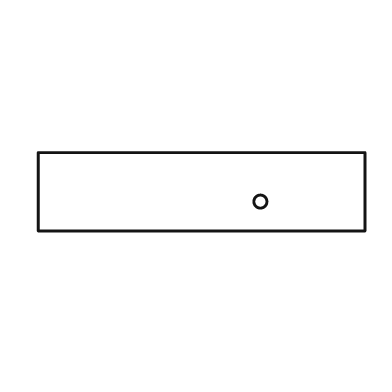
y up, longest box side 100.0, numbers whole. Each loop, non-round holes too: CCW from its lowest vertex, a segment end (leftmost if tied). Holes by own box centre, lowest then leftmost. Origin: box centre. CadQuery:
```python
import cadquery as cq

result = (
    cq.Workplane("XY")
    .moveTo(-50.0, -12.0)
    .lineTo(50.0, -12.0)
    .lineTo(50.0, 12.0)
    .lineTo(-50.0, 12.0)
    .close()
    .moveTo(18.0, -3.0)
    .circle(2.0)
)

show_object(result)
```